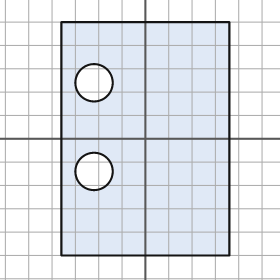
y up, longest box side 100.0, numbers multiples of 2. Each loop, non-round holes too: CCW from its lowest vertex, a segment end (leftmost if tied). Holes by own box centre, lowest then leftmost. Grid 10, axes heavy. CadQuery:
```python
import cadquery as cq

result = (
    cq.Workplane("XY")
    .moveTo(-36.0, -50.0)
    .lineTo(36.0, -50.0)
    .lineTo(36.0, 50.0)
    .lineTo(-36.0, 50.0)
    .close()
    .moveTo(-22.0, -14.0)
    .circle(8.0)
    .moveTo(-22.0, 24.0)
    .circle(8.0)
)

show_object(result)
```